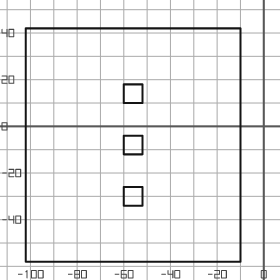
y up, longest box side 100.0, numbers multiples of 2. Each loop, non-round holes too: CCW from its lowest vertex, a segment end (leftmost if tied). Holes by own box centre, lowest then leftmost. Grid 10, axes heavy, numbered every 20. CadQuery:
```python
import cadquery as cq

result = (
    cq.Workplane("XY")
    .moveTo(-102.0, -58.0)
    .lineTo(-10.0, -58.0)
    .lineTo(-10.0, 42.0)
    .lineTo(-102.0, 42.0)
    .close()
    .moveTo(-60.0, -34.0)
    .lineTo(-52.0, -34.0)
    .lineTo(-52.0, -26.0)
    .lineTo(-60.0, -26.0)
    .close()
    .moveTo(-60.0, -12.0)
    .lineTo(-52.0, -12.0)
    .lineTo(-52.0, -4.0)
    .lineTo(-60.0, -4.0)
    .close()
    .moveTo(-60.0, 10.0)
    .lineTo(-52.0, 10.0)
    .lineTo(-52.0, 18.0)
    .lineTo(-60.0, 18.0)
    .close()
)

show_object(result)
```